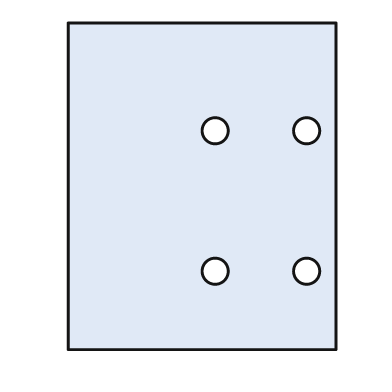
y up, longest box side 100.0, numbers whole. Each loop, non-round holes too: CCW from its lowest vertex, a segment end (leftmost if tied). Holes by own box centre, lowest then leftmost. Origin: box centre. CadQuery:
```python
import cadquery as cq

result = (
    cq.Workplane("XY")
    .moveTo(-41.0, -50.0)
    .lineTo(41.0, -50.0)
    .lineTo(41.0, 50.0)
    .lineTo(-41.0, 50.0)
    .close()
    .moveTo(4.0, -26.0)
    .circle(4.0)
    .moveTo(32.0, -26.0)
    .circle(4.0)
    .moveTo(4.0, 17.0)
    .circle(4.0)
    .moveTo(32.0, 17.0)
    .circle(4.0)
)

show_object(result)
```